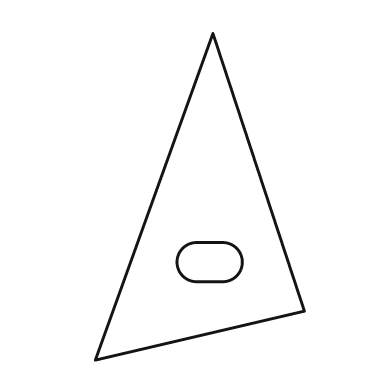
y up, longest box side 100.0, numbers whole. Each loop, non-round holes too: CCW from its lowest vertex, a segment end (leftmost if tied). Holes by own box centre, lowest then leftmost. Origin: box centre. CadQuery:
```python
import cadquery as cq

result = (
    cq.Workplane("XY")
    .moveTo(-32.0, -50.0)
    .lineTo(32.0, -35.0)
    .lineTo(4.0, 50.0)
    .close()
    .moveTo(-1.0, -26.0)
    .lineTo(7.0, -26.0)
    .threePointArc((13.0, -20.0), (7.0, -14.0))
    .lineTo(-1.0, -14.0)
    .threePointArc((-7.0, -20.0), (-1.0, -26.0))
    .close()
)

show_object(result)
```